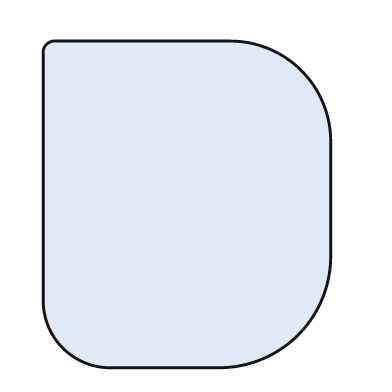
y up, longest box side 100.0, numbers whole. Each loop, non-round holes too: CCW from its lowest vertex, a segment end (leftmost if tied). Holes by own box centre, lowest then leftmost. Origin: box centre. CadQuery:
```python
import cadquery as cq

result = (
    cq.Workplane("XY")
    .moveTo(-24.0, -50.0)
    .lineTo(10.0, -50.0)
    .threePointArc((34.0, -40.0), (44.0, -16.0))
    .lineTo(44.0, 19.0)
    .threePointArc((35.0, 41.0), (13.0, 50.0))
    .lineTo(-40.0, 50.0)
    .threePointArc((-43.0, 49.0), (-44.0, 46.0))
    .lineTo(-44.0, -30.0)
    .threePointArc((-38.0, -44.0), (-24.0, -50.0))
    .close()
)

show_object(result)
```